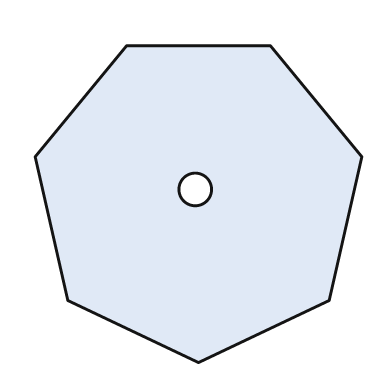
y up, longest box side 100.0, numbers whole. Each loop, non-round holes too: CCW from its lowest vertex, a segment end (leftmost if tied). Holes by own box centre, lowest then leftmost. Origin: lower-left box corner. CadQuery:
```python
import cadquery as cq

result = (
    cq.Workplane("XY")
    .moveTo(50.0, 0.0)
    .lineTo(90.0, 19.0)
    .lineTo(100.0, 63.0)
    .lineTo(72.0, 97.0)
    .lineTo(28.0, 97.0)
    .lineTo(0.0, 63.0)
    .lineTo(10.0, 19.0)
    .close()
    .moveTo(49.0, 53.0)
    .circle(5.0)
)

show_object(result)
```